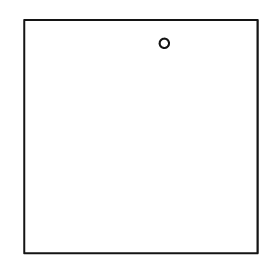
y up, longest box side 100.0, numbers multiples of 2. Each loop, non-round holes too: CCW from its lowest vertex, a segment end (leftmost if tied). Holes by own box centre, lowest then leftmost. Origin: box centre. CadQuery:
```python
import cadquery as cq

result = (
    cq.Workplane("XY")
    .moveTo(-50.0, -50.0)
    .lineTo(50.0, -50.0)
    .lineTo(50.0, 50.0)
    .lineTo(-50.0, 50.0)
    .close()
    .moveTo(10.0, 40.0)
    .circle(2.0)
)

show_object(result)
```